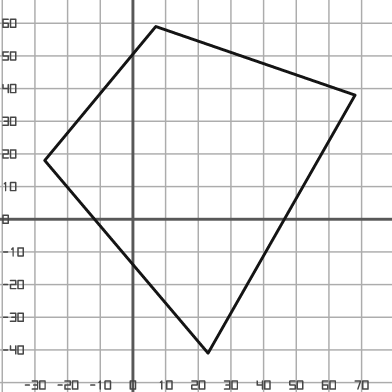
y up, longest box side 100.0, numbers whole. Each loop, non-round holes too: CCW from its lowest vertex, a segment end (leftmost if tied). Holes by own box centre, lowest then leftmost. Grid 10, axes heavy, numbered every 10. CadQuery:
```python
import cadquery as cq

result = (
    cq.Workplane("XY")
    .moveTo(23.0, -41.0)
    .lineTo(68.0, 38.0)
    .lineTo(7.0, 59.0)
    .lineTo(-27.0, 18.0)
    .close()
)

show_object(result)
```